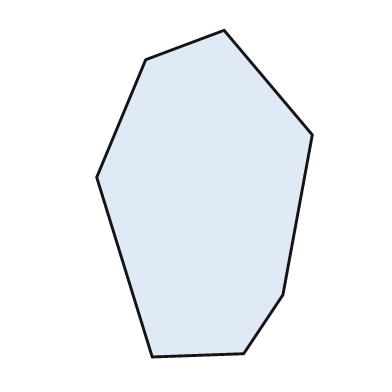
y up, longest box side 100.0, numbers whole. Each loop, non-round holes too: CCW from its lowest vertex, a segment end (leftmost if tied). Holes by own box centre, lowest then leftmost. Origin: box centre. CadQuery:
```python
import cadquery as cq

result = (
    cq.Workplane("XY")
    .moveTo(-16.0, -50.0)
    .lineTo(12.0, -49.0)
    .lineTo(24.0, -31.0)
    .lineTo(33.0, 18.0)
    .lineTo(6.0, 50.0)
    .lineTo(-18.0, 41.0)
    .lineTo(-33.0, 5.0)
    .close()
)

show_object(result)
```